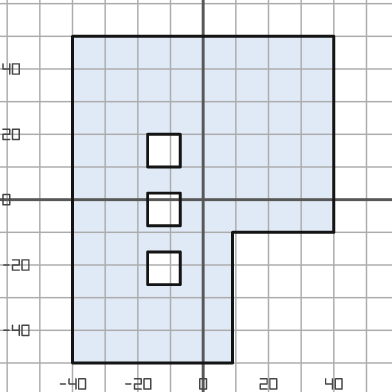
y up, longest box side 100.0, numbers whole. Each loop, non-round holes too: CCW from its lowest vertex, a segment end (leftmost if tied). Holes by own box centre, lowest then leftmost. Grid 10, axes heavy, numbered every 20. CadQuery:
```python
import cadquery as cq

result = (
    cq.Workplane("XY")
    .moveTo(-40.0, -50.0)
    .lineTo(9.0, -50.0)
    .lineTo(9.0, -10.0)
    .lineTo(40.0, -10.0)
    .lineTo(40.0, 50.0)
    .lineTo(-40.0, 50.0)
    .close()
    .moveTo(-17.0, -26.0)
    .lineTo(-7.0, -26.0)
    .lineTo(-7.0, -16.0)
    .lineTo(-17.0, -16.0)
    .close()
    .moveTo(-17.0, -8.0)
    .lineTo(-7.0, -8.0)
    .lineTo(-7.0, 2.0)
    .lineTo(-17.0, 2.0)
    .close()
    .moveTo(-17.0, 10.0)
    .lineTo(-7.0, 10.0)
    .lineTo(-7.0, 20.0)
    .lineTo(-17.0, 20.0)
    .close()
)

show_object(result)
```